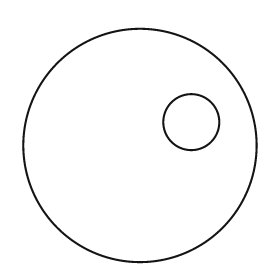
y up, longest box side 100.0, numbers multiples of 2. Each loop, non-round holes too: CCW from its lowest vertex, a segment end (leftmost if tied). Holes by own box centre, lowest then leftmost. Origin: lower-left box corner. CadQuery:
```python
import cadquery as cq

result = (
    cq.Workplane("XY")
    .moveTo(50.0, 50.0)
    .circle(50.0)
    .moveTo(72.0, 60.0)
    .circle(12.0)
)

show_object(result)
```